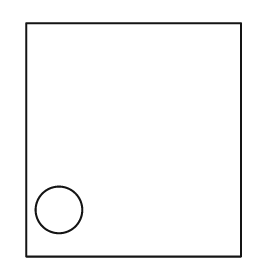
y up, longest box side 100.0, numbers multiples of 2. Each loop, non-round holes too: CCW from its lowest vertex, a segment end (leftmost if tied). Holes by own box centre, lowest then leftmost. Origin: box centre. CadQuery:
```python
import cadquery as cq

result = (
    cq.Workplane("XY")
    .moveTo(-46.0, -50.0)
    .lineTo(46.0, -50.0)
    .lineTo(46.0, 50.0)
    .lineTo(-46.0, 50.0)
    .close()
    .moveTo(-32.0, -30.0)
    .circle(10.0)
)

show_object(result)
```